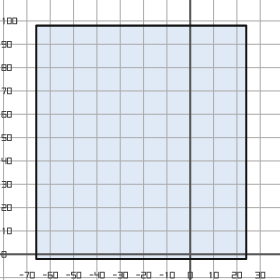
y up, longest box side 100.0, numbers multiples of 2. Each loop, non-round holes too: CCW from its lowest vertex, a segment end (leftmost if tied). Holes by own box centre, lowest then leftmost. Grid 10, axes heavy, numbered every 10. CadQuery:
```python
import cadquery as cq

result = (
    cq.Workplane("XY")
    .moveTo(-66.0, -2.0)
    .lineTo(24.0, -2.0)
    .lineTo(24.0, 98.0)
    .lineTo(-66.0, 98.0)
    .close()
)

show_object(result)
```